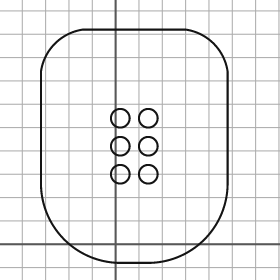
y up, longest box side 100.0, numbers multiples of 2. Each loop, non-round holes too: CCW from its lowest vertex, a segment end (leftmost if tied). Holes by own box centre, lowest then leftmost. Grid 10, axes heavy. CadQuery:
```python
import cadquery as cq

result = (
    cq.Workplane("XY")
    .moveTo(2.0, -8.0)
    .lineTo(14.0, -8.0)
    .threePointArc((38.0, 2.0), (48.0, 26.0))
    .lineTo(48.0, 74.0)
    .threePointArc((42.0, 86.0), (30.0, 92.0))
    .lineTo(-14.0, 92.0)
    .threePointArc((-26.0, 86.0), (-32.0, 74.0))
    .lineTo(-32.0, 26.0)
    .threePointArc((-22.0, 2.0), (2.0, -8.0))
    .close()
    .moveTo(2.0, 30.0)
    .circle(4.0)
    .moveTo(14.0, 30.0)
    .circle(4.0)
    .moveTo(2.0, 42.0)
    .circle(4.0)
    .moveTo(14.0, 42.0)
    .circle(4.0)
    .moveTo(2.0, 54.0)
    .circle(4.0)
    .moveTo(14.0, 54.0)
    .circle(4.0)
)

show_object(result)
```